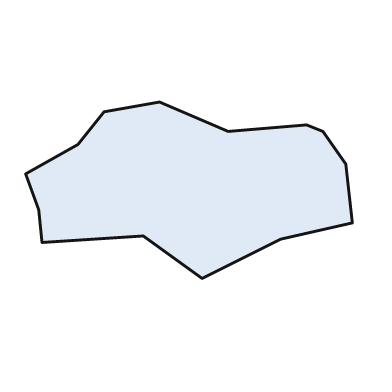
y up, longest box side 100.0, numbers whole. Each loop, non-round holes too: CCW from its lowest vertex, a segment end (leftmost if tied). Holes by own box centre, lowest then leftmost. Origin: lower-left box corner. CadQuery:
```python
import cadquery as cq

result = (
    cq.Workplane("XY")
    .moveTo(54.0, 0.0)
    .lineTo(78.0, 12.0)
    .lineTo(100.0, 17.0)
    .lineTo(98.0, 35.0)
    .lineTo(91.0, 45.0)
    .lineTo(86.0, 47.0)
    .lineTo(62.0, 45.0)
    .lineTo(41.0, 54.0)
    .lineTo(24.0, 51.0)
    .lineTo(16.0, 41.0)
    .lineTo(0.0, 32.0)
    .lineTo(4.0, 21.0)
    .lineTo(5.0, 11.0)
    .lineTo(36.0, 13.0)
    .close()
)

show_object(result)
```